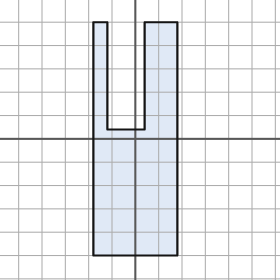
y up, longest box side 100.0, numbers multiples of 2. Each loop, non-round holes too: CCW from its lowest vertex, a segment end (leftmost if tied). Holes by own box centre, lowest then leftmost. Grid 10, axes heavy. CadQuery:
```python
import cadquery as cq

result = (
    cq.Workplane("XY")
    .moveTo(-18.0, -50.0)
    .lineTo(18.0, -50.0)
    .lineTo(18.0, 50.0)
    .lineTo(4.0, 50.0)
    .lineTo(4.0, 4.0)
    .lineTo(-12.0, 4.0)
    .lineTo(-12.0, 50.0)
    .lineTo(-18.0, 50.0)
    .close()
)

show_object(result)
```